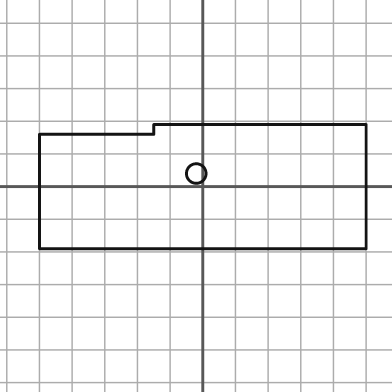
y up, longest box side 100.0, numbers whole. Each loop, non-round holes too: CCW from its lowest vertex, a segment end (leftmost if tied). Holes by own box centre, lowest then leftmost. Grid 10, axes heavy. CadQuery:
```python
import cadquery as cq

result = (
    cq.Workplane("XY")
    .moveTo(-50.0, -19.0)
    .lineTo(50.0, -19.0)
    .lineTo(50.0, 19.0)
    .lineTo(-15.0, 19.0)
    .lineTo(-15.0, 16.0)
    .lineTo(-50.0, 16.0)
    .close()
    .moveTo(-2.0, 4.0)
    .circle(3.0)
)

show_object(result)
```